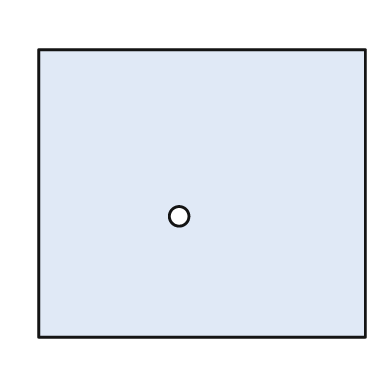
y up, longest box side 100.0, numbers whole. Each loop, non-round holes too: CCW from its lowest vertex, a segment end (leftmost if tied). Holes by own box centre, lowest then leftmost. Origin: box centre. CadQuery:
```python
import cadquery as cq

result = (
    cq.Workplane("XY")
    .moveTo(-50.0, -44.0)
    .lineTo(50.0, -44.0)
    .lineTo(50.0, 44.0)
    .lineTo(-50.0, 44.0)
    .close()
    .moveTo(-7.0, -7.0)
    .circle(3.0)
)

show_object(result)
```